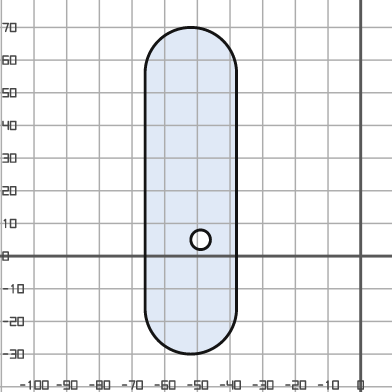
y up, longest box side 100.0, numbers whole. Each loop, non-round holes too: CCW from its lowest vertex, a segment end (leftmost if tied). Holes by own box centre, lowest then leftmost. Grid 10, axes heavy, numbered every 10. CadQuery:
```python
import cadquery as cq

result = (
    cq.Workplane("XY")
    .moveTo(-66.0, -16.0)
    .threePointArc((-52.0, -30.0), (-38.0, -16.0))
    .lineTo(-38.0, 56.0)
    .threePointArc((-52.0, 70.0), (-66.0, 56.0))
    .close()
    .moveTo(-49.0, 5.0)
    .circle(3.0)
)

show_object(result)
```